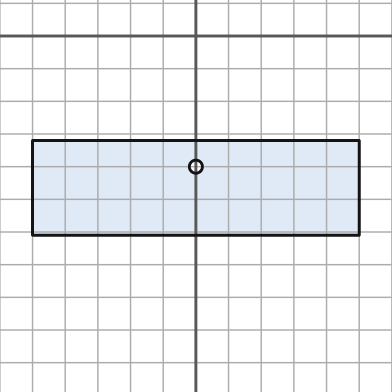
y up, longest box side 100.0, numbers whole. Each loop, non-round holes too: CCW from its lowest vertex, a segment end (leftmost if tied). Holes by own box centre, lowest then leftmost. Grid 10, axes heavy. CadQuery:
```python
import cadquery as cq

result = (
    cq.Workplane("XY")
    .moveTo(-50.0, -61.0)
    .lineTo(50.0, -61.0)
    .lineTo(50.0, -32.0)
    .lineTo(-50.0, -32.0)
    .close()
    .moveTo(0.0, -40.0)
    .circle(2.0)
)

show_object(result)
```